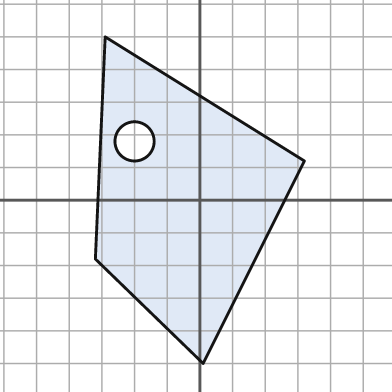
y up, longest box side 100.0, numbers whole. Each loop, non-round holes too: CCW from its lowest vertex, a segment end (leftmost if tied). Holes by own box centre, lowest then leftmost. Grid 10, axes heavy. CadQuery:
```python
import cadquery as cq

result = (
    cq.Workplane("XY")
    .moveTo(1.0, -50.0)
    .lineTo(32.0, 12.0)
    .lineTo(-29.0, 50.0)
    .lineTo(-32.0, -18.0)
    .close()
    .moveTo(-20.0, 18.0)
    .circle(6.0)
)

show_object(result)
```